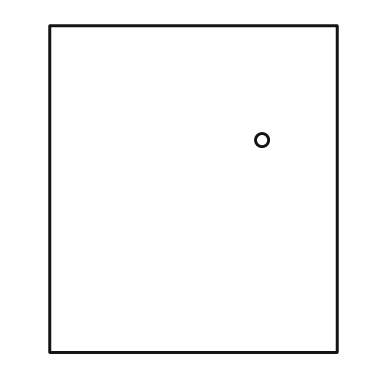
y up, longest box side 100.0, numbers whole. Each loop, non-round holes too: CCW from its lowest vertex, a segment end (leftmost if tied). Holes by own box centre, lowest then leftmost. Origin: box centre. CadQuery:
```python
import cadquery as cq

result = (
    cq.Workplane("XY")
    .moveTo(-44.0, -50.0)
    .lineTo(44.0, -50.0)
    .lineTo(44.0, 50.0)
    .lineTo(-44.0, 50.0)
    .close()
    .moveTo(21.0, 15.0)
    .circle(2.0)
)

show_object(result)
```